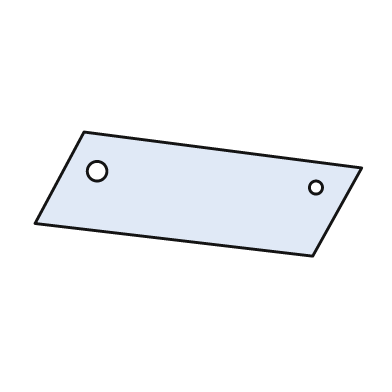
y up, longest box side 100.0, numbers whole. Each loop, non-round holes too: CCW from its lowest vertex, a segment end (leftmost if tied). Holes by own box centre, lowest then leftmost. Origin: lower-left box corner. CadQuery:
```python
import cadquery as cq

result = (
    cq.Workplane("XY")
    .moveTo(85.0, 0.0)
    .lineTo(100.0, 27.0)
    .lineTo(15.0, 38.0)
    .lineTo(0.0, 10.0)
    .close()
    .moveTo(86.0, 21.0)
    .circle(2.0)
    .moveTo(19.0, 26.0)
    .circle(3.0)
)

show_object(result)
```